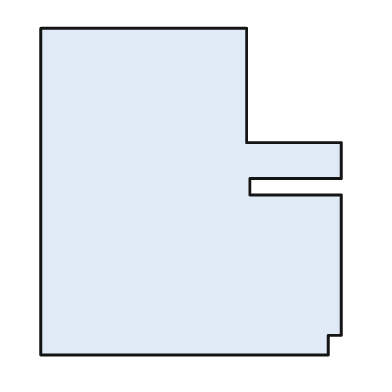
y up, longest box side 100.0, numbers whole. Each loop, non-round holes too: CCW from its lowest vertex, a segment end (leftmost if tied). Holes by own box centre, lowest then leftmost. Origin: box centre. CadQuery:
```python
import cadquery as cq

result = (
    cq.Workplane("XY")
    .moveTo(-46.0, -50.0)
    .lineTo(42.0, -50.0)
    .lineTo(42.0, -44.0)
    .lineTo(46.0, -44.0)
    .lineTo(46.0, -1.0)
    .lineTo(18.0, -1.0)
    .lineTo(18.0, 4.0)
    .lineTo(46.0, 4.0)
    .lineTo(46.0, 15.0)
    .lineTo(17.0, 15.0)
    .lineTo(17.0, 50.0)
    .lineTo(-46.0, 50.0)
    .close()
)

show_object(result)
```